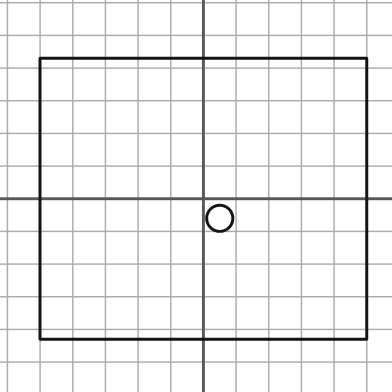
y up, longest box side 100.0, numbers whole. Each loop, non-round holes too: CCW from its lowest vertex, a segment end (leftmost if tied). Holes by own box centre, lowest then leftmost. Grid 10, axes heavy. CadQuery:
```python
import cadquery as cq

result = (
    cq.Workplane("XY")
    .moveTo(-50.0, -43.0)
    .lineTo(50.0, -43.0)
    .lineTo(50.0, 43.0)
    .lineTo(-50.0, 43.0)
    .close()
    .moveTo(5.0, -6.0)
    .circle(4.0)
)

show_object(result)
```